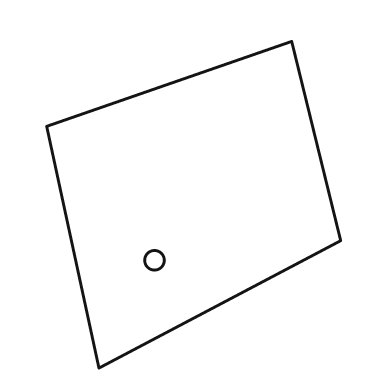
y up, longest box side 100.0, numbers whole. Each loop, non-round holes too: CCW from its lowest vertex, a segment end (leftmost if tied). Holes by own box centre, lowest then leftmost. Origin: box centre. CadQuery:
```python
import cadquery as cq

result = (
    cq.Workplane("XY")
    .moveTo(-29.0, -50.0)
    .lineTo(45.0, -11.0)
    .lineTo(30.0, 50.0)
    .lineTo(-45.0, 24.0)
    .close()
    .moveTo(-12.0, -17.0)
    .circle(3.0)
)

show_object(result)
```